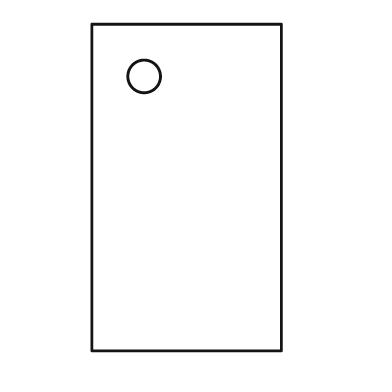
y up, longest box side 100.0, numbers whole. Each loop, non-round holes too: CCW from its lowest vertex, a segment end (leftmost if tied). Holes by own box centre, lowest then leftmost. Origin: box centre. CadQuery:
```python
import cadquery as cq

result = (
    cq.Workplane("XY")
    .moveTo(-29.0, -50.0)
    .lineTo(29.0, -50.0)
    .lineTo(29.0, 50.0)
    .lineTo(-29.0, 50.0)
    .close()
    .moveTo(-13.0, 34.0)
    .circle(5.0)
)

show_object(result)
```